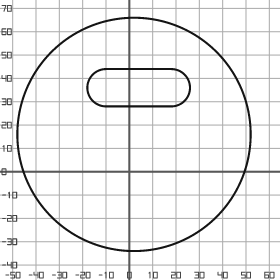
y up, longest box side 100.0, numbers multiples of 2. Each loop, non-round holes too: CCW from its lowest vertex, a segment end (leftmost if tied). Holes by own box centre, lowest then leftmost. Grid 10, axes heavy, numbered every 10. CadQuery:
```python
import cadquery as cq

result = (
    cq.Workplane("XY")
    .moveTo(2.0, 16.0)
    .circle(50.0)
    .moveTo(-10.0, 28.0)
    .lineTo(18.0, 28.0)
    .threePointArc((26.0, 36.0), (18.0, 44.0))
    .lineTo(-10.0, 44.0)
    .threePointArc((-18.0, 36.0), (-10.0, 28.0))
    .close()
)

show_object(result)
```